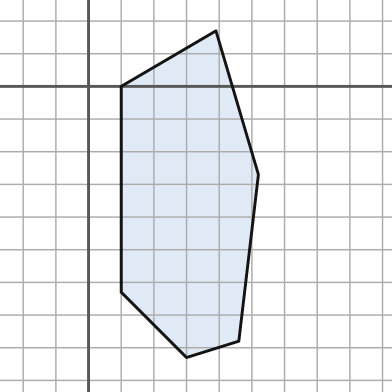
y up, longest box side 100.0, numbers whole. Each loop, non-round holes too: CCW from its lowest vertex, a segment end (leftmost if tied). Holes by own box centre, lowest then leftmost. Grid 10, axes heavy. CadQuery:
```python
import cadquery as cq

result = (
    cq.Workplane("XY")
    .moveTo(30.0, -83.0)
    .lineTo(46.0, -78.0)
    .lineTo(52.0, -27.0)
    .lineTo(39.0, 17.0)
    .lineTo(10.0, 0.0)
    .lineTo(10.0, -63.0)
    .close()
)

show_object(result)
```